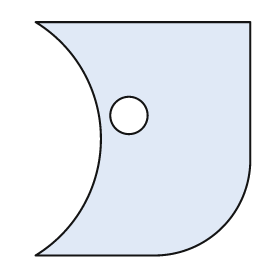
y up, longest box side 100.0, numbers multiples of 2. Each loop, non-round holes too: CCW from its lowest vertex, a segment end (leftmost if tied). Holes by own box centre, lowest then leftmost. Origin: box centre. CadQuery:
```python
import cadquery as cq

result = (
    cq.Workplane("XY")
    .moveTo(-46.0, -50.0)
    .lineTo(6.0, -50.0)
    .threePointArc((34.0, -38.0), (46.0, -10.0))
    .lineTo(46.0, 50.0)
    .lineTo(-46.0, 50.0)
    .threePointArc((-18.0, 0.0), (-46.0, -50.0))
    .close()
    .moveTo(-6.0, 10.0)
    .circle(8.0)
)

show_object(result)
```